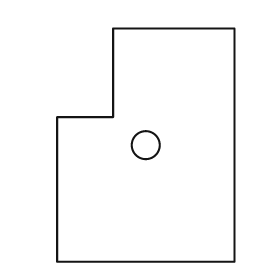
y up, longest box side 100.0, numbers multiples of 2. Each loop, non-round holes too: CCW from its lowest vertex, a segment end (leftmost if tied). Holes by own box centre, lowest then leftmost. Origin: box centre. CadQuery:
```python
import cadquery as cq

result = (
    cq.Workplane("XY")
    .moveTo(-38.0, -50.0)
    .lineTo(38.0, -50.0)
    .lineTo(38.0, 50.0)
    .lineTo(-14.0, 50.0)
    .lineTo(-14.0, 12.0)
    .lineTo(-38.0, 12.0)
    .close()
    .moveTo(0.0, 0.0)
    .circle(6.0)
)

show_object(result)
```